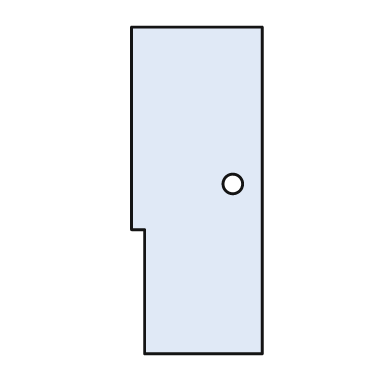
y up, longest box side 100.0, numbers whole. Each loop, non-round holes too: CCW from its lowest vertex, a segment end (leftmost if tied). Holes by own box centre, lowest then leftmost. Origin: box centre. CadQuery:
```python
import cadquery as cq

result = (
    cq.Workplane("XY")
    .moveTo(-16.0, -50.0)
    .lineTo(20.0, -50.0)
    .lineTo(20.0, 50.0)
    .lineTo(-20.0, 50.0)
    .lineTo(-20.0, -12.0)
    .lineTo(-16.0, -12.0)
    .close()
    .moveTo(11.0, 2.0)
    .circle(3.0)
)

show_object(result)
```